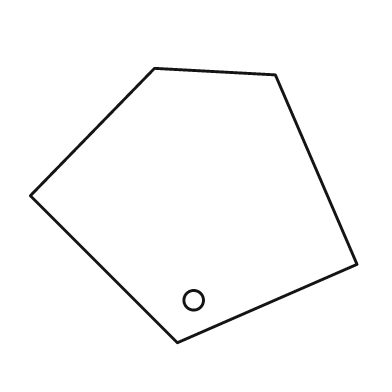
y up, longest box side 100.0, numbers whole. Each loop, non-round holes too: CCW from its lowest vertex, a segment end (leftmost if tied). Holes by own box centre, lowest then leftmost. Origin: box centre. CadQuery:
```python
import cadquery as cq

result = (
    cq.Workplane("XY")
    .moveTo(-5.0, -42.0)
    .lineTo(50.0, -18.0)
    .lineTo(25.0, 40.0)
    .lineTo(-12.0, 42.0)
    .lineTo(-50.0, 3.0)
    .close()
    .moveTo(0.0, -29.0)
    .circle(3.0)
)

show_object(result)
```